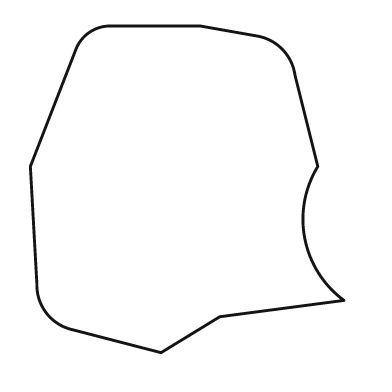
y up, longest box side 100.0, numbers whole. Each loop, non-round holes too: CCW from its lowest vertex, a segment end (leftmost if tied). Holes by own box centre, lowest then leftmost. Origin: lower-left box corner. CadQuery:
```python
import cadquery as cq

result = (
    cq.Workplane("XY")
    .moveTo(40.0, 0.0)
    .lineTo(58.0, 11.0)
    .lineTo(96.0, 16.0)
    .threePointArc((84.0, 35.0), (88.0, 57.0))
    .lineTo(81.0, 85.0)
    .threePointArc((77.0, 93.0), (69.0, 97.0))
    .lineTo(52.0, 100.0)
    .lineTo(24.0, 100.0)
    .threePointArc((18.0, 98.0), (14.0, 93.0))
    .lineTo(0.0, 57.0)
    .lineTo(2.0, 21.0)
    .threePointArc((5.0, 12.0), (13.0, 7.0))
    .close()
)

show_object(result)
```